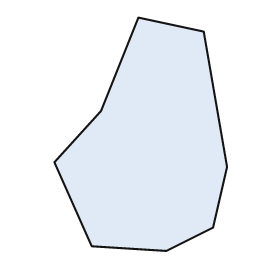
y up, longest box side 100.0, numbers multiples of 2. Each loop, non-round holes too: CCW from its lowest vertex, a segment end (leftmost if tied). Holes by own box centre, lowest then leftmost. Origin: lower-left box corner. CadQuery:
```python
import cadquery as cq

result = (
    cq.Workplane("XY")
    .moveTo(48.0, 0.0)
    .lineTo(68.0, 10.0)
    .lineTo(74.0, 36.0)
    .lineTo(64.0, 94.0)
    .lineTo(36.0, 100.0)
    .lineTo(20.0, 60.0)
    .lineTo(0.0, 38.0)
    .lineTo(16.0, 2.0)
    .close()
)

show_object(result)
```